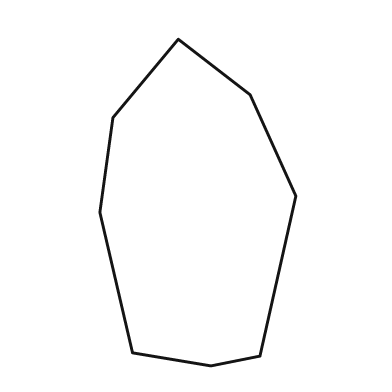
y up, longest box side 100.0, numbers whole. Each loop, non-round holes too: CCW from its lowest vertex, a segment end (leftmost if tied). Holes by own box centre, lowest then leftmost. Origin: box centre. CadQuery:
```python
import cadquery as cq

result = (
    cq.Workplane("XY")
    .moveTo(4.0, -50.0)
    .lineTo(19.0, -47.0)
    .lineTo(30.0, 2.0)
    .lineTo(16.0, 33.0)
    .lineTo(-6.0, 50.0)
    .lineTo(-26.0, 26.0)
    .lineTo(-30.0, -3.0)
    .lineTo(-20.0, -46.0)
    .close()
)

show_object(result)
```